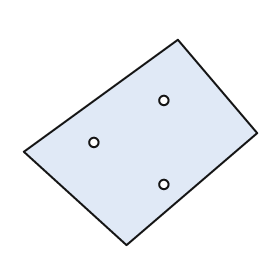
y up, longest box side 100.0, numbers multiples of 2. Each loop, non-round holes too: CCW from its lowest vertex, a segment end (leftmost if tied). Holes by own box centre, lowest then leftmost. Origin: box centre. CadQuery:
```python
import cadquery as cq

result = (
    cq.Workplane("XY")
    .moveTo(-6.0, -44.0)
    .lineTo(50.0, 4.0)
    .lineTo(16.0, 44.0)
    .lineTo(-50.0, -4.0)
    .close()
    .moveTo(10.0, -18.0)
    .circle(2.0)
    .moveTo(-20.0, 0.0)
    .circle(2.0)
    .moveTo(10.0, 18.0)
    .circle(2.0)
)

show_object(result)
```